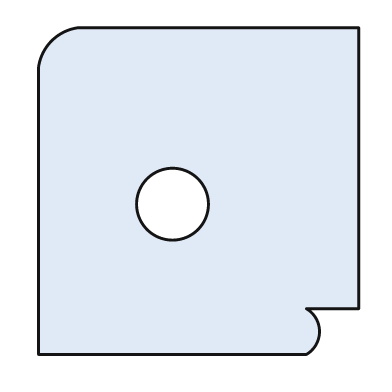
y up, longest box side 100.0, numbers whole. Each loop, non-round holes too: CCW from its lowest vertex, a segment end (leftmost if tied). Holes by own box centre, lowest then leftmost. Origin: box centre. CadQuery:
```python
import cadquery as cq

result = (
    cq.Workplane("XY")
    .moveTo(-49.0, -50.0)
    .lineTo(33.0, -50.0)
    .threePointArc((37.0, -43.0), (33.0, -36.0))
    .lineTo(49.0, -36.0)
    .lineTo(49.0, 50.0)
    .lineTo(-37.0, 50.0)
    .threePointArc((-45.0, 46.0), (-49.0, 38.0))
    .close()
    .moveTo(-8.0, -4.0)
    .circle(11.0)
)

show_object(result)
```